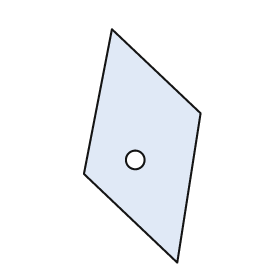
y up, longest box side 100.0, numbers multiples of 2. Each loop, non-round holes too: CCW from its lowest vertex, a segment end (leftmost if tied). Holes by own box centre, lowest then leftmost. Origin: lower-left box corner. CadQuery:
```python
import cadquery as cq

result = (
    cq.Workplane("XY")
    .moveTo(40.0, 0.0)
    .lineTo(50.0, 64.0)
    .lineTo(12.0, 100.0)
    .lineTo(0.0, 38.0)
    .close()
    .moveTo(22.0, 44.0)
    .circle(4.0)
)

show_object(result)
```